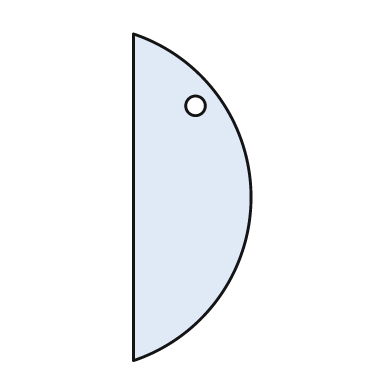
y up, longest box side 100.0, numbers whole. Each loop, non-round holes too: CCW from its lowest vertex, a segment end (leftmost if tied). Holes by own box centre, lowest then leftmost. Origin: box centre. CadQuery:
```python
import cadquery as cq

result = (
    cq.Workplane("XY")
    .moveTo(-18.0, -50.0)
    .threePointArc((18.0, 0.0), (-18.0, 50.0))
    .close()
    .moveTo(1.0, 28.0)
    .circle(3.0)
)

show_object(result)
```